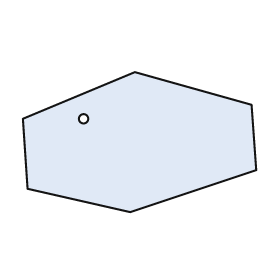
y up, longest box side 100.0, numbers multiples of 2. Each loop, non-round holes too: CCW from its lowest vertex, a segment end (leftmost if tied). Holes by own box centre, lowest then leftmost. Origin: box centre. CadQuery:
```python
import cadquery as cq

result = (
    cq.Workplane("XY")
    .moveTo(-4.0, -30.0)
    .lineTo(50.0, -12.0)
    .lineTo(48.0, 16.0)
    .lineTo(-2.0, 30.0)
    .lineTo(-50.0, 10.0)
    .lineTo(-48.0, -20.0)
    .close()
    .moveTo(-24.0, 10.0)
    .circle(2.0)
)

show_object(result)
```